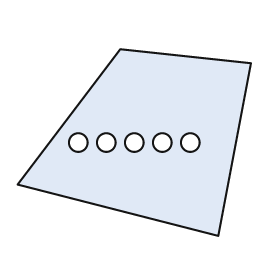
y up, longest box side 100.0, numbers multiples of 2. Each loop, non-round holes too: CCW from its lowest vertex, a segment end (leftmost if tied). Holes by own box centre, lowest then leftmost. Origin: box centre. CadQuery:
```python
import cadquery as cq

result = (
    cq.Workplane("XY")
    .moveTo(36.0, -40.0)
    .lineTo(50.0, 34.0)
    .lineTo(-6.0, 40.0)
    .lineTo(-50.0, -18.0)
    .close()
    .moveTo(-24.0, 0.0)
    .circle(4.0)
    .moveTo(-12.0, 0.0)
    .circle(4.0)
    .moveTo(0.0, 0.0)
    .circle(4.0)
    .moveTo(12.0, 0.0)
    .circle(4.0)
    .moveTo(24.0, 0.0)
    .circle(4.0)
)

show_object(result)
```